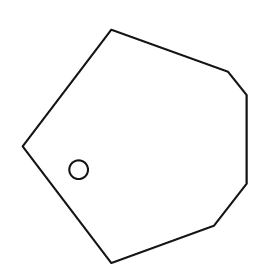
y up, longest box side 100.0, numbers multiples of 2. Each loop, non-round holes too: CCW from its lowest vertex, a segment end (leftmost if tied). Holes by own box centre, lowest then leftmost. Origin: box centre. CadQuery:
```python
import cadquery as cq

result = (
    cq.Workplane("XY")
    .moveTo(-10.0, -50.0)
    .lineTo(34.0, -34.0)
    .lineTo(48.0, -16.0)
    .lineTo(48.0, 22.0)
    .lineTo(40.0, 32.0)
    .lineTo(-10.0, 50.0)
    .lineTo(-48.0, 0.0)
    .close()
    .moveTo(-24.0, -10.0)
    .circle(4.0)
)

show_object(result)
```